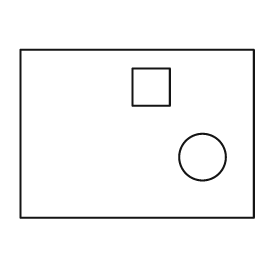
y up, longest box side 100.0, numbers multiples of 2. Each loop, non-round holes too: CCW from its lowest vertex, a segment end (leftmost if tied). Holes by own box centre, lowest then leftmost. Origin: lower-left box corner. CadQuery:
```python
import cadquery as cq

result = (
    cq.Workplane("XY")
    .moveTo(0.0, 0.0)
    .lineTo(100.0, 0.0)
    .lineTo(100.0, 72.0)
    .lineTo(0.0, 72.0)
    .close()
    .moveTo(78.0, 26.0)
    .circle(10.0)
    .moveTo(48.0, 48.0)
    .lineTo(64.0, 48.0)
    .lineTo(64.0, 64.0)
    .lineTo(48.0, 64.0)
    .close()
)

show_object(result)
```